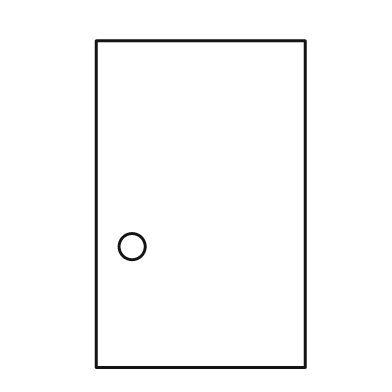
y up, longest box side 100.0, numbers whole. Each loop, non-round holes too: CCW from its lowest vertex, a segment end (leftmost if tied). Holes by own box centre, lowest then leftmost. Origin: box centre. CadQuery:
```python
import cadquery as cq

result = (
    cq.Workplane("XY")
    .moveTo(-32.0, -50.0)
    .lineTo(32.0, -50.0)
    .lineTo(32.0, 50.0)
    .lineTo(-32.0, 50.0)
    .close()
    .moveTo(-21.0, -13.0)
    .circle(4.0)
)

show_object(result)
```